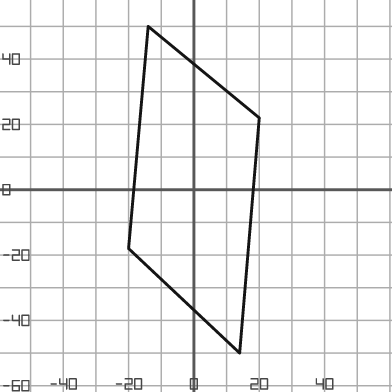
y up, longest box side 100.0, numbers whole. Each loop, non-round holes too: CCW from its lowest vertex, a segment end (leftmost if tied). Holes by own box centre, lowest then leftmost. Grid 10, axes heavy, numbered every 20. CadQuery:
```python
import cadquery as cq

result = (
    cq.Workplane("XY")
    .moveTo(14.0, -50.0)
    .lineTo(20.0, 22.0)
    .lineTo(-14.0, 50.0)
    .lineTo(-20.0, -18.0)
    .close()
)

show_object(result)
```